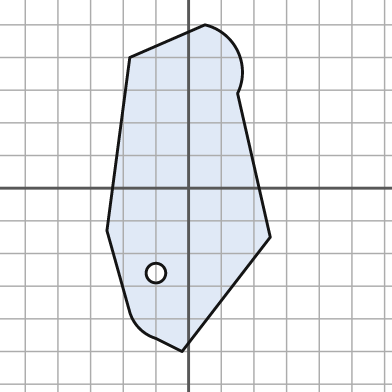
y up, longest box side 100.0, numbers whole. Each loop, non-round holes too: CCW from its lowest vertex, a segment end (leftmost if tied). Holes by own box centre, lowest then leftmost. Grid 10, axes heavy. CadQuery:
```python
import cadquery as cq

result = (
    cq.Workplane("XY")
    .moveTo(-2.0, -50.0)
    .lineTo(25.0, -15.0)
    .lineTo(15.0, 29.0)
    .threePointArc((15.0, 42.0), (5.0, 50.0))
    .lineTo(-18.0, 40.0)
    .lineTo(-25.0, -13.0)
    .lineTo(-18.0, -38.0)
    .threePointArc((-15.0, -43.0), (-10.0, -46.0))
    .close()
    .moveTo(-10.0, -26.0)
    .circle(3.0)
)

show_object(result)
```